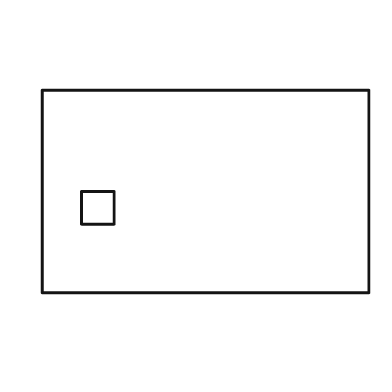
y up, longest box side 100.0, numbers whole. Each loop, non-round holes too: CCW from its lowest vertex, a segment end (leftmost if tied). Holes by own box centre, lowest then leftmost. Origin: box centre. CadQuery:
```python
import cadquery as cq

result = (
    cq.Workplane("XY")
    .moveTo(-50.0, -31.0)
    .lineTo(50.0, -31.0)
    .lineTo(50.0, 31.0)
    .lineTo(-50.0, 31.0)
    .close()
    .moveTo(-38.0, -10.0)
    .lineTo(-28.0, -10.0)
    .lineTo(-28.0, 0.0)
    .lineTo(-38.0, 0.0)
    .close()
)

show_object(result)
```